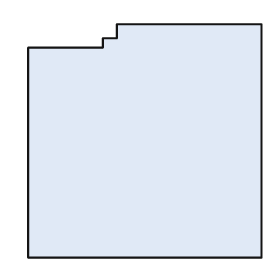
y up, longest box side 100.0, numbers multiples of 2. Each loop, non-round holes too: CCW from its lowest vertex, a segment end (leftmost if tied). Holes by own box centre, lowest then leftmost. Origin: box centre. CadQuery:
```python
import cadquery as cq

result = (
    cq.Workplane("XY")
    .moveTo(-50.0, -50.0)
    .lineTo(50.0, -50.0)
    .lineTo(50.0, 50.0)
    .lineTo(-12.0, 50.0)
    .lineTo(-12.0, 44.0)
    .lineTo(-18.0, 44.0)
    .lineTo(-18.0, 40.0)
    .lineTo(-50.0, 40.0)
    .close()
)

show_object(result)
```